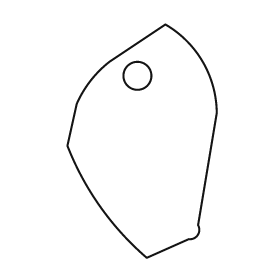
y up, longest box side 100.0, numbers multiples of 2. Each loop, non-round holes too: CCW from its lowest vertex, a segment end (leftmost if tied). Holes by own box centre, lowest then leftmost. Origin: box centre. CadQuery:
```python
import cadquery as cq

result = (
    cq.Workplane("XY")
    .moveTo(2.0, -50.0)
    .lineTo(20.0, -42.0)
    .threePointArc((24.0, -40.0), (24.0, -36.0))
    .lineTo(32.0, 12.0)
    .threePointArc((26.0, 34.0), (10.0, 50.0))
    .lineTo(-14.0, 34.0)
    .threePointArc((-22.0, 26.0), (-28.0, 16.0))
    .lineTo(-32.0, -2.0)
    .threePointArc((-18.0, -28.0), (2.0, -50.0))
    .close()
    .moveTo(-2.0, 28.0)
    .circle(6.0)
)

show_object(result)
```